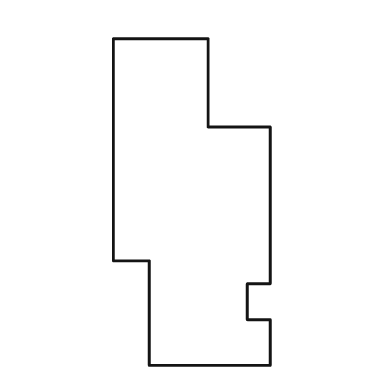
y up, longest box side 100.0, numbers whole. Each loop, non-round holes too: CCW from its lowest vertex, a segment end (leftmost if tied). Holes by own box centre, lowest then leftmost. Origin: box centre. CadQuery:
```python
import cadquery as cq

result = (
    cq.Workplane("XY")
    .moveTo(-13.0, -50.0)
    .lineTo(24.0, -50.0)
    .lineTo(24.0, -36.0)
    .lineTo(17.0, -36.0)
    .lineTo(17.0, -25.0)
    .lineTo(24.0, -25.0)
    .lineTo(24.0, 23.0)
    .lineTo(5.0, 23.0)
    .lineTo(5.0, 50.0)
    .lineTo(-24.0, 50.0)
    .lineTo(-24.0, -18.0)
    .lineTo(-13.0, -18.0)
    .close()
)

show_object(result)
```